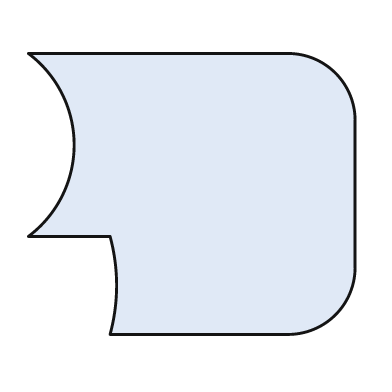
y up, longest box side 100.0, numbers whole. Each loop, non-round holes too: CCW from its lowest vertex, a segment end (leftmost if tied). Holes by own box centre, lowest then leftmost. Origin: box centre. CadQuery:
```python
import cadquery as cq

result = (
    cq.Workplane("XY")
    .moveTo(-25.0, -43.0)
    .lineTo(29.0, -43.0)
    .threePointArc((44.0, -37.0), (50.0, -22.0))
    .lineTo(50.0, 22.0)
    .threePointArc((44.0, 37.0), (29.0, 43.0))
    .lineTo(-50.0, 43.0)
    .threePointArc((-36.0, 15.0), (-50.0, -13.0))
    .lineTo(-25.0, -13.0)
    .threePointArc((-23.0, -28.0), (-25.0, -43.0))
    .close()
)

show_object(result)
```